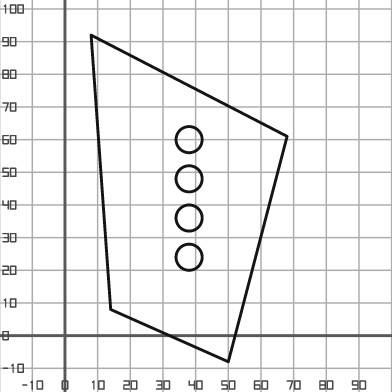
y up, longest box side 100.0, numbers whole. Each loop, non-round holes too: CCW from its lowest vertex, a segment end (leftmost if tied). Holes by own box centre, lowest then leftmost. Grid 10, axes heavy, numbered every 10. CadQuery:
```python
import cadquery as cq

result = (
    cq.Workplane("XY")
    .moveTo(50.0, -8.0)
    .lineTo(68.0, 61.0)
    .lineTo(8.0, 92.0)
    .lineTo(14.0, 8.0)
    .close()
    .moveTo(38.0, 24.0)
    .circle(4.0)
    .moveTo(38.0, 36.0)
    .circle(4.0)
    .moveTo(38.0, 48.0)
    .circle(4.0)
    .moveTo(38.0, 60.0)
    .circle(4.0)
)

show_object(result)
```